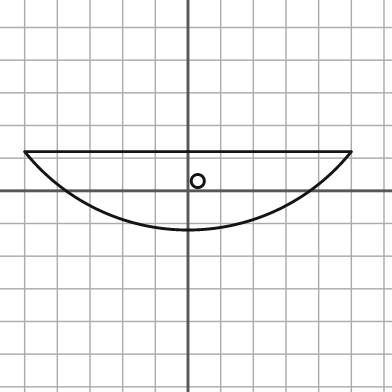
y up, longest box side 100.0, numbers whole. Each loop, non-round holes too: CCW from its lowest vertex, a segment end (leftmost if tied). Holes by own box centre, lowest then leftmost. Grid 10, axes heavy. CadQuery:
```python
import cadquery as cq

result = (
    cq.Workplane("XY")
    .moveTo(-50.0, 12.0)
    .threePointArc((0.0, -12.0), (50.0, 12.0))
    .close()
    .moveTo(3.0, 3.0)
    .circle(2.0)
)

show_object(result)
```